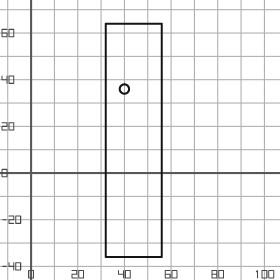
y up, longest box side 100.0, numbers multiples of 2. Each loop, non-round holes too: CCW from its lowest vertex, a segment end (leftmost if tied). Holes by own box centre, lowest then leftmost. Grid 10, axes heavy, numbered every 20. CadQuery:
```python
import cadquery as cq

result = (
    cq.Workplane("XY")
    .moveTo(32.0, -36.0)
    .lineTo(56.0, -36.0)
    .lineTo(56.0, 64.0)
    .lineTo(32.0, 64.0)
    .close()
    .moveTo(40.0, 36.0)
    .circle(2.0)
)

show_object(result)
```